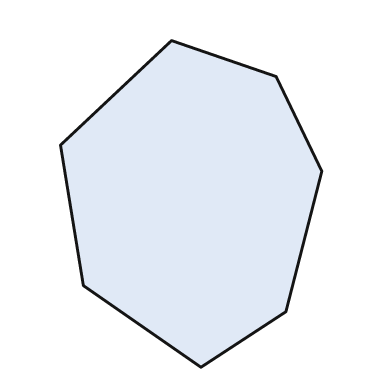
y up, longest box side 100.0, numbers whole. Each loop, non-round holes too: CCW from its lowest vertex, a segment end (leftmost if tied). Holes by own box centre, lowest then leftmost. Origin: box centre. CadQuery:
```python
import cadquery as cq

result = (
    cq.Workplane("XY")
    .moveTo(3.0, -50.0)
    .lineTo(29.0, -33.0)
    .lineTo(40.0, 10.0)
    .lineTo(26.0, 39.0)
    .lineTo(-6.0, 50.0)
    .lineTo(-40.0, 18.0)
    .lineTo(-33.0, -25.0)
    .close()
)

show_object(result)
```